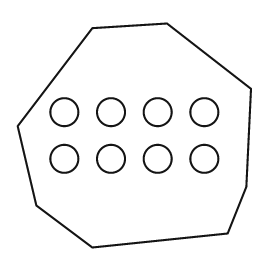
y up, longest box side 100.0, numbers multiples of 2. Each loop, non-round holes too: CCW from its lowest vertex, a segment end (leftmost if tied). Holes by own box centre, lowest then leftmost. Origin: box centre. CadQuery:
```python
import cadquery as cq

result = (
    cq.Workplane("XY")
    .moveTo(-18.0, -48.0)
    .lineTo(40.0, -42.0)
    .lineTo(48.0, -22.0)
    .lineTo(50.0, 20.0)
    .lineTo(14.0, 48.0)
    .lineTo(-18.0, 46.0)
    .lineTo(-50.0, 4.0)
    .lineTo(-42.0, -30.0)
    .close()
    .moveTo(-30.0, -10.0)
    .circle(6.0)
    .moveTo(-10.0, -10.0)
    .circle(6.0)
    .moveTo(10.0, -10.0)
    .circle(6.0)
    .moveTo(30.0, -10.0)
    .circle(6.0)
    .moveTo(-30.0, 10.0)
    .circle(6.0)
    .moveTo(-10.0, 10.0)
    .circle(6.0)
    .moveTo(10.0, 10.0)
    .circle(6.0)
    .moveTo(30.0, 10.0)
    .circle(6.0)
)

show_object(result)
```